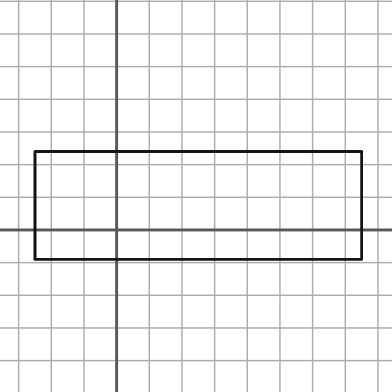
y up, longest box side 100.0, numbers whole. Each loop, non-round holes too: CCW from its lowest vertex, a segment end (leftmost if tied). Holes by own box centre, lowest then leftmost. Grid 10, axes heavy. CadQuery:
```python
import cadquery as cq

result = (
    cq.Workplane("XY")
    .moveTo(-25.0, -9.0)
    .lineTo(75.0, -9.0)
    .lineTo(75.0, 24.0)
    .lineTo(-25.0, 24.0)
    .close()
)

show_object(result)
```